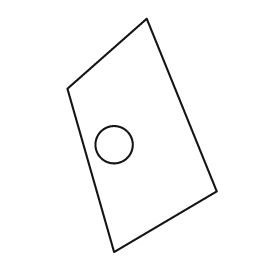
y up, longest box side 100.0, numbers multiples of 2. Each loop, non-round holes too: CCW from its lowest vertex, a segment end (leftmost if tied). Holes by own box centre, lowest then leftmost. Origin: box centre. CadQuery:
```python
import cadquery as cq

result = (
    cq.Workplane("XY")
    .moveTo(-12.0, -50.0)
    .lineTo(32.0, -24.0)
    .lineTo(2.0, 50.0)
    .lineTo(-32.0, 20.0)
    .close()
    .moveTo(-12.0, -4.0)
    .circle(8.0)
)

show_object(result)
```